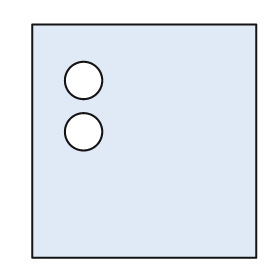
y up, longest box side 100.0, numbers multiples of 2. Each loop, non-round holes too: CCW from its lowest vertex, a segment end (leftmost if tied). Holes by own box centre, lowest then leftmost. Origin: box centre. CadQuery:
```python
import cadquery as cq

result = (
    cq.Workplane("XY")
    .moveTo(-48.0, -50.0)
    .lineTo(48.0, -50.0)
    .lineTo(48.0, 50.0)
    .lineTo(-48.0, 50.0)
    .close()
    .moveTo(-26.0, 4.0)
    .circle(8.0)
    .moveTo(-26.0, 26.0)
    .circle(8.0)
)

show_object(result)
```